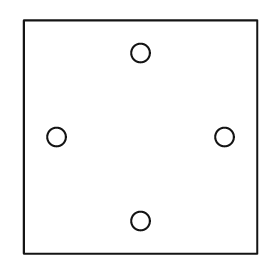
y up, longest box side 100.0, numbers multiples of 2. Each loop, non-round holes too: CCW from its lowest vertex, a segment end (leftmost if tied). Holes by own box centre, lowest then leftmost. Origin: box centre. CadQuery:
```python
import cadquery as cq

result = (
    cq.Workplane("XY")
    .moveTo(-50.0, -50.0)
    .lineTo(50.0, -50.0)
    .lineTo(50.0, 50.0)
    .lineTo(-50.0, 50.0)
    .close()
    .moveTo(0.0, -36.0)
    .circle(4.0)
    .moveTo(-36.0, 0.0)
    .circle(4.0)
    .moveTo(36.0, 0.0)
    .circle(4.0)
    .moveTo(0.0, 36.0)
    .circle(4.0)
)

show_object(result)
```